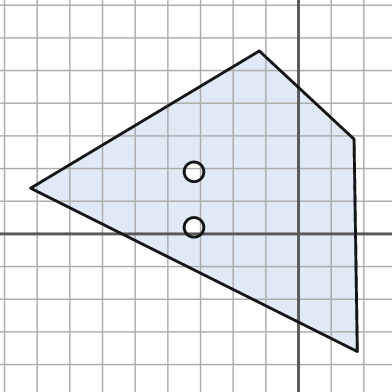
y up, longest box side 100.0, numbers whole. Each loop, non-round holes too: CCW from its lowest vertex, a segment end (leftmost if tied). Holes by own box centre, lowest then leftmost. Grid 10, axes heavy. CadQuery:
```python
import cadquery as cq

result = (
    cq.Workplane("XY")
    .moveTo(18.0, -36.0)
    .lineTo(17.0, 29.0)
    .lineTo(-12.0, 56.0)
    .lineTo(-82.0, 14.0)
    .close()
    .moveTo(-32.0, 2.0)
    .circle(3.0)
    .moveTo(-32.0, 19.0)
    .circle(3.0)
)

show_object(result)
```